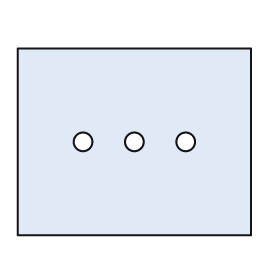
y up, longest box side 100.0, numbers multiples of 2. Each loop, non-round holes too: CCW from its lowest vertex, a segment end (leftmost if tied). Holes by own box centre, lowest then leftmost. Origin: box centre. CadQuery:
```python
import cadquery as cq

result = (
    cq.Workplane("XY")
    .moveTo(-50.0, -40.0)
    .lineTo(50.0, -40.0)
    .lineTo(50.0, 40.0)
    .lineTo(-50.0, 40.0)
    .close()
    .moveTo(-22.0, 0.0)
    .circle(4.0)
    .moveTo(0.0, 0.0)
    .circle(4.0)
    .moveTo(22.0, 0.0)
    .circle(4.0)
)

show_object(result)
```